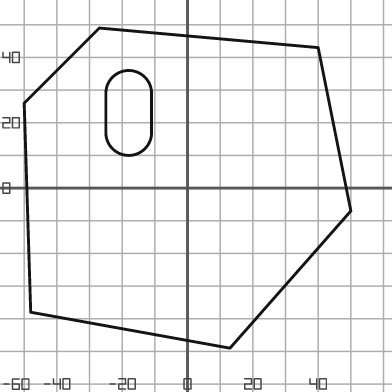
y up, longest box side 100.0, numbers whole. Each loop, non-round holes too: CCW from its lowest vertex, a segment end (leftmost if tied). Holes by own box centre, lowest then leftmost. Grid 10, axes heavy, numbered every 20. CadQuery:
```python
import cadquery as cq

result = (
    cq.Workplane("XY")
    .moveTo(13.0, -49.0)
    .lineTo(50.0, -7.0)
    .lineTo(40.0, 43.0)
    .lineTo(-27.0, 49.0)
    .lineTo(-50.0, 26.0)
    .lineTo(-48.0, -38.0)
    .close()
    .moveTo(-25.0, 17.0)
    .threePointArc((-18.0, 10.0), (-11.0, 17.0))
    .lineTo(-11.0, 29.0)
    .threePointArc((-18.0, 36.0), (-25.0, 29.0))
    .close()
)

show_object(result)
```